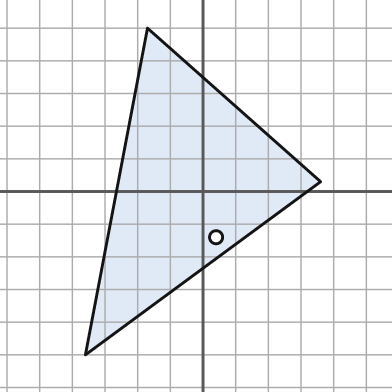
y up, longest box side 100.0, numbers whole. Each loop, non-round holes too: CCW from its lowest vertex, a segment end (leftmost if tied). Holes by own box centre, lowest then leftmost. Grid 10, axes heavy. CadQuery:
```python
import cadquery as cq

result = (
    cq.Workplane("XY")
    .moveTo(-36.0, -50.0)
    .lineTo(36.0, 3.0)
    .lineTo(-17.0, 50.0)
    .close()
    .moveTo(4.0, -14.0)
    .circle(2.0)
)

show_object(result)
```